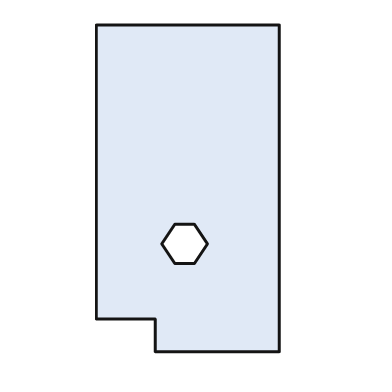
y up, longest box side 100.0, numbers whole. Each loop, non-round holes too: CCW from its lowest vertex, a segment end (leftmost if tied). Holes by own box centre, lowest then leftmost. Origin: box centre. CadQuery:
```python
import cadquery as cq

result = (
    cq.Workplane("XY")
    .moveTo(-10.0, -50.0)
    .lineTo(28.0, -50.0)
    .lineTo(28.0, 50.0)
    .lineTo(-28.0, 50.0)
    .lineTo(-28.0, -40.0)
    .lineTo(-10.0, -40.0)
    .close()
    .moveTo(-4.0, -23.0)
    .lineTo(2.0, -23.0)
    .lineTo(6.0, -17.0)
    .lineTo(2.0, -11.0)
    .lineTo(-4.0, -11.0)
    .lineTo(-8.0, -17.0)
    .close()
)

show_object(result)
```